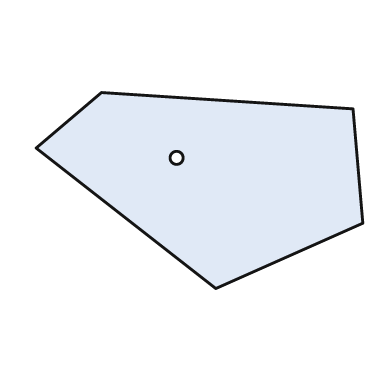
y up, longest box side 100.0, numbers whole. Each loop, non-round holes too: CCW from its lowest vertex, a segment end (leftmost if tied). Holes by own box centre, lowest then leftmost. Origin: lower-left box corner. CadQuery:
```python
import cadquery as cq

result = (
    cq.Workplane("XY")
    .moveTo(55.0, 0.0)
    .lineTo(100.0, 20.0)
    .lineTo(97.0, 55.0)
    .lineTo(20.0, 60.0)
    .lineTo(0.0, 43.0)
    .close()
    .moveTo(43.0, 40.0)
    .circle(2.0)
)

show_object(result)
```